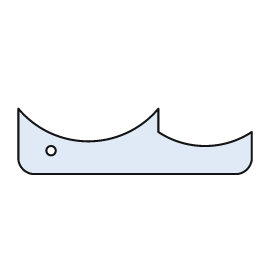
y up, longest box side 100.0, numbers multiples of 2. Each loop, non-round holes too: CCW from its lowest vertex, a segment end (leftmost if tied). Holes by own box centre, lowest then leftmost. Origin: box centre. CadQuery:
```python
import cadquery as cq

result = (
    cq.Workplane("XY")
    .moveTo(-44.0, -14.0)
    .lineTo(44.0, -14.0)
    .threePointArc((48.0, -12.0), (50.0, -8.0))
    .lineTo(50.0, 4.0)
    .threePointArc((30.0, -2.0), (10.0, 4.0))
    .lineTo(10.0, 14.0)
    .threePointArc((-20.0, 0.0), (-50.0, 14.0))
    .lineTo(-50.0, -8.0)
    .threePointArc((-48.0, -12.0), (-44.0, -14.0))
    .close()
    .moveTo(-36.0, -4.0)
    .circle(2.0)
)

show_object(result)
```